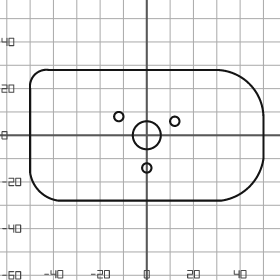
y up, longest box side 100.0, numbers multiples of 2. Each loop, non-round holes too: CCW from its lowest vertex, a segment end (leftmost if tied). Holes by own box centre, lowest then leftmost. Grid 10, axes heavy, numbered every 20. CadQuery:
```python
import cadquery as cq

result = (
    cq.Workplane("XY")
    .moveTo(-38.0, -28.0)
    .lineTo(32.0, -28.0)
    .threePointArc((44.0, -22.0), (50.0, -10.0))
    .lineTo(50.0, 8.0)
    .threePointArc((44.0, 22.0), (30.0, 28.0))
    .lineTo(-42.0, 28.0)
    .threePointArc((-48.0, 26.0), (-50.0, 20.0))
    .lineTo(-50.0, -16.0)
    .threePointArc((-46.0, -24.0), (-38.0, -28.0))
    .close()
    .moveTo(0.0, -14.0)
    .circle(2.0)
    .moveTo(0.0, 0.0)
    .circle(6.0)
    .moveTo(12.0, 6.0)
    .circle(2.0)
    .moveTo(-12.0, 8.0)
    .circle(2.0)
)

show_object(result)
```